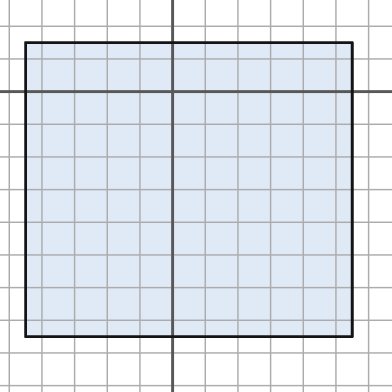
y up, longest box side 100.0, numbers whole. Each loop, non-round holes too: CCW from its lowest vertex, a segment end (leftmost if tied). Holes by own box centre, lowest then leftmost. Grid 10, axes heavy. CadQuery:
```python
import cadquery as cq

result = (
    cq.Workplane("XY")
    .moveTo(-45.0, -75.0)
    .lineTo(55.0, -75.0)
    .lineTo(55.0, 15.0)
    .lineTo(-45.0, 15.0)
    .close()
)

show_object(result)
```